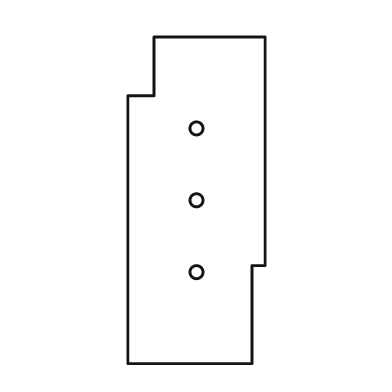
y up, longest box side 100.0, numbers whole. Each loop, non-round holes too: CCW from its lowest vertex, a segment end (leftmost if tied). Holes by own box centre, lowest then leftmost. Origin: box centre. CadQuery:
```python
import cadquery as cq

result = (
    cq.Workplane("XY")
    .moveTo(-21.0, -50.0)
    .lineTo(17.0, -50.0)
    .lineTo(17.0, -20.0)
    .lineTo(21.0, -20.0)
    .lineTo(21.0, 50.0)
    .lineTo(-13.0, 50.0)
    .lineTo(-13.0, 32.0)
    .lineTo(-21.0, 32.0)
    .close()
    .moveTo(0.0, -22.0)
    .circle(2.0)
    .moveTo(0.0, 0.0)
    .circle(2.0)
    .moveTo(0.0, 22.0)
    .circle(2.0)
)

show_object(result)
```